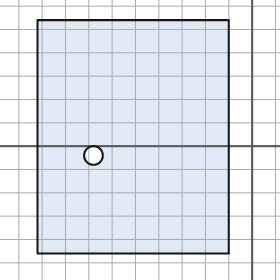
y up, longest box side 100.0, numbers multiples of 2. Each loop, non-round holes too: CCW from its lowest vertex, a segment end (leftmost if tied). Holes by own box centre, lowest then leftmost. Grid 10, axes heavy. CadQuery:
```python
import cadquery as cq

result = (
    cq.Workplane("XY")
    .moveTo(-92.0, -46.0)
    .lineTo(-10.0, -46.0)
    .lineTo(-10.0, 54.0)
    .lineTo(-92.0, 54.0)
    .close()
    .moveTo(-68.0, -4.0)
    .circle(4.0)
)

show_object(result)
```